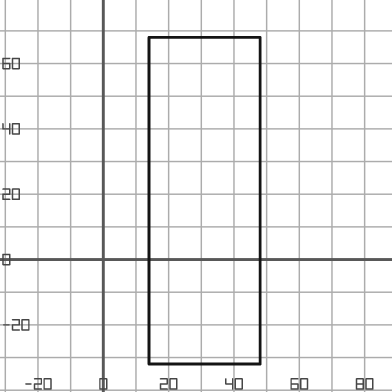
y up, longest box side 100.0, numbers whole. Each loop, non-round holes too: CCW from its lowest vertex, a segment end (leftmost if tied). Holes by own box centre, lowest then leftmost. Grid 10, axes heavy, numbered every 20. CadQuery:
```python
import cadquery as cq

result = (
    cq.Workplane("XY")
    .moveTo(14.0, -32.0)
    .lineTo(48.0, -32.0)
    .lineTo(48.0, 68.0)
    .lineTo(14.0, 68.0)
    .close()
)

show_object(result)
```